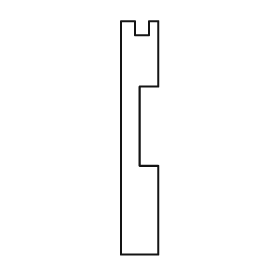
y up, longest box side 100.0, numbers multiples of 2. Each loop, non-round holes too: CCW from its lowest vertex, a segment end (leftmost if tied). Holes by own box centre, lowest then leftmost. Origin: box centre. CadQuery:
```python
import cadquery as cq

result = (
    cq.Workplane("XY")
    .moveTo(-8.0, -50.0)
    .lineTo(8.0, -50.0)
    .lineTo(8.0, -12.0)
    .lineTo(0.0, -12.0)
    .lineTo(0.0, 22.0)
    .lineTo(8.0, 22.0)
    .lineTo(8.0, 50.0)
    .lineTo(4.0, 50.0)
    .lineTo(4.0, 44.0)
    .lineTo(-2.0, 44.0)
    .lineTo(-2.0, 50.0)
    .lineTo(-8.0, 50.0)
    .close()
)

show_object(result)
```